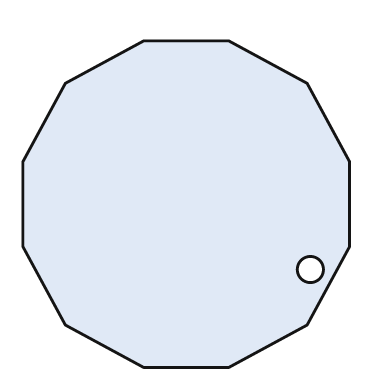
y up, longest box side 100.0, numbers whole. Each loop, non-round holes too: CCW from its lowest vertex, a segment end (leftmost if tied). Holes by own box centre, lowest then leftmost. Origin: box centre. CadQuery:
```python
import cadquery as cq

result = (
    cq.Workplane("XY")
    .moveTo(-13.0, -50.0)
    .lineTo(13.0, -50.0)
    .lineTo(37.0, -37.0)
    .lineTo(50.0, -13.0)
    .lineTo(50.0, 13.0)
    .lineTo(37.0, 37.0)
    .lineTo(13.0, 50.0)
    .lineTo(-13.0, 50.0)
    .lineTo(-37.0, 37.0)
    .lineTo(-50.0, 13.0)
    .lineTo(-50.0, -13.0)
    .lineTo(-37.0, -37.0)
    .close()
    .moveTo(38.0, -20.0)
    .circle(4.0)
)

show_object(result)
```